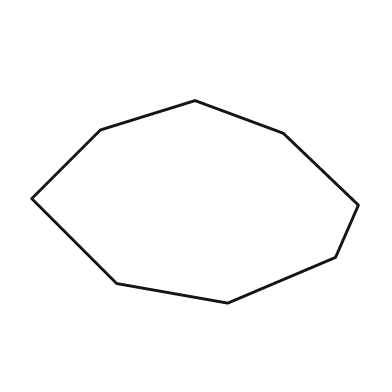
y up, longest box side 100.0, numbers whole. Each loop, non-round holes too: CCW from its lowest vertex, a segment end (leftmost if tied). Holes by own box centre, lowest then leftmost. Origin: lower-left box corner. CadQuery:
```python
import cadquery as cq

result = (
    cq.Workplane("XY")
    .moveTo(60.0, 0.0)
    .lineTo(93.0, 14.0)
    .lineTo(100.0, 30.0)
    .lineTo(77.0, 52.0)
    .lineTo(50.0, 62.0)
    .lineTo(21.0, 53.0)
    .lineTo(0.0, 32.0)
    .lineTo(26.0, 6.0)
    .close()
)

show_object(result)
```